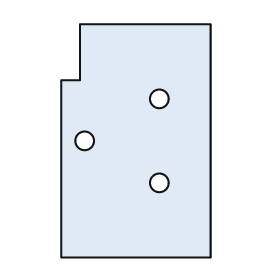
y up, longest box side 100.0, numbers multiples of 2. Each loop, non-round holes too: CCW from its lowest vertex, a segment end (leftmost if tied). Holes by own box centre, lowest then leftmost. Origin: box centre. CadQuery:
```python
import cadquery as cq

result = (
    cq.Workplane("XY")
    .moveTo(-32.0, -50.0)
    .lineTo(32.0, -50.0)
    .lineTo(32.0, 50.0)
    .lineTo(-24.0, 50.0)
    .lineTo(-24.0, 26.0)
    .lineTo(-32.0, 26.0)
    .close()
    .moveTo(10.0, -18.0)
    .circle(4.0)
    .moveTo(-22.0, 0.0)
    .circle(4.0)
    .moveTo(10.0, 18.0)
    .circle(4.0)
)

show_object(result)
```